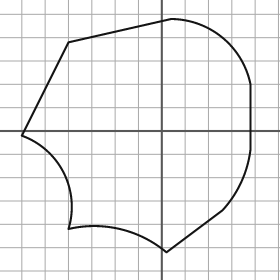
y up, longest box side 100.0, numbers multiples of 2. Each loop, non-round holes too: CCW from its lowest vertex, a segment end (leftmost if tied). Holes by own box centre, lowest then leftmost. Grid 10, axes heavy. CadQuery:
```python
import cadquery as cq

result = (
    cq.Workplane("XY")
    .moveTo(2.0, -52.0)
    .lineTo(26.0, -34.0)
    .threePointArc((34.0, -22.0), (38.0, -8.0))
    .lineTo(38.0, 20.0)
    .threePointArc((26.0, 40.0), (4.0, 48.0))
    .lineTo(-40.0, 38.0)
    .lineTo(-60.0, -2.0)
    .threePointArc((-42.0, -18.0), (-40.0, -42.0))
    .threePointArc((-18.0, -42.0), (2.0, -52.0))
    .close()
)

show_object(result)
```